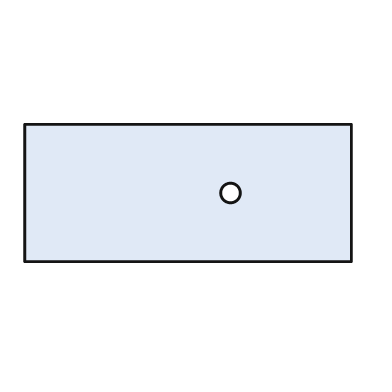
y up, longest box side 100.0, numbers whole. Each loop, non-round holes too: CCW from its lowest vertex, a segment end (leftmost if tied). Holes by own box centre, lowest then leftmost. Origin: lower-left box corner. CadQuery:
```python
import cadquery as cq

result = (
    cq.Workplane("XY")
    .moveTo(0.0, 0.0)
    .lineTo(100.0, 0.0)
    .lineTo(100.0, 42.0)
    .lineTo(0.0, 42.0)
    .close()
    .moveTo(63.0, 21.0)
    .circle(3.0)
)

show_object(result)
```